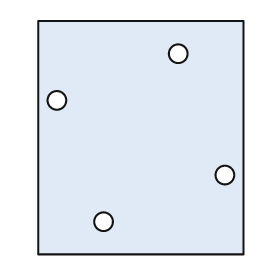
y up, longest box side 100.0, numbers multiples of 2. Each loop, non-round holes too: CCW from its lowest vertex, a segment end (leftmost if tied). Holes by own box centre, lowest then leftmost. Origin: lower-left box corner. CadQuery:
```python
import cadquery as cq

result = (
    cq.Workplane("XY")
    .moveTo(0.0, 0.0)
    .lineTo(88.0, 0.0)
    .lineTo(88.0, 100.0)
    .lineTo(0.0, 100.0)
    .close()
    .moveTo(28.0, 14.0)
    .circle(4.0)
    .moveTo(80.0, 34.0)
    .circle(4.0)
    .moveTo(8.0, 66.0)
    .circle(4.0)
    .moveTo(60.0, 86.0)
    .circle(4.0)
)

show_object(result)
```